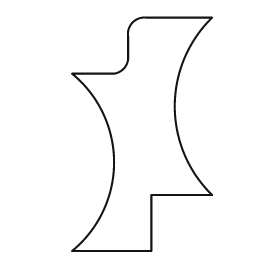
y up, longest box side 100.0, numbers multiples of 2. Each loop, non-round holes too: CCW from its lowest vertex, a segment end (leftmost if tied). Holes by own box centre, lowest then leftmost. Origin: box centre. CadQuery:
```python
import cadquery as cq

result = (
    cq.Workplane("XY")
    .moveTo(-30.0, -50.0)
    .lineTo(4.0, -50.0)
    .lineTo(4.0, -26.0)
    .lineTo(30.0, -26.0)
    .threePointArc((14.0, 12.0), (30.0, 50.0))
    .lineTo(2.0, 50.0)
    .threePointArc((-4.0, 48.0), (-6.0, 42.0))
    .lineTo(-6.0, 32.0)
    .threePointArc((-8.0, 28.0), (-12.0, 26.0))
    .lineTo(-30.0, 26.0)
    .threePointArc((-12.0, -12.0), (-30.0, -50.0))
    .close()
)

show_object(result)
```